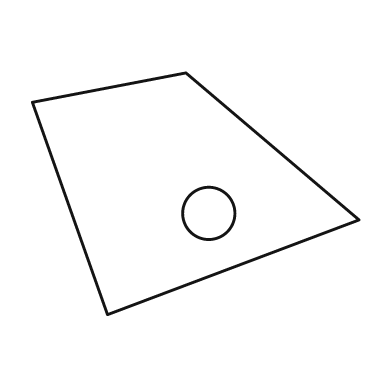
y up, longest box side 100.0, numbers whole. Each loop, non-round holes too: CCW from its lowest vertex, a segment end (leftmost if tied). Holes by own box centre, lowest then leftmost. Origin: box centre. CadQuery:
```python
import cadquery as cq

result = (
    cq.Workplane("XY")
    .moveTo(-27.0, -37.0)
    .lineTo(50.0, -8.0)
    .lineTo(-3.0, 37.0)
    .lineTo(-50.0, 28.0)
    .close()
    .moveTo(4.0, -6.0)
    .circle(8.0)
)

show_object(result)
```